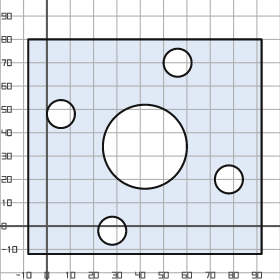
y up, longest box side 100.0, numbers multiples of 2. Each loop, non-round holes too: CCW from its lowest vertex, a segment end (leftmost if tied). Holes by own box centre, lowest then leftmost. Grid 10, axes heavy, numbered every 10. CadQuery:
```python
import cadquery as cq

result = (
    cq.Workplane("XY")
    .moveTo(-8.0, -12.0)
    .lineTo(92.0, -12.0)
    .lineTo(92.0, 80.0)
    .lineTo(-8.0, 80.0)
    .close()
    .moveTo(28.0, -2.0)
    .circle(6.0)
    .moveTo(78.0, 20.0)
    .circle(6.0)
    .moveTo(42.0, 34.0)
    .circle(18.0)
    .moveTo(6.0, 48.0)
    .circle(6.0)
    .moveTo(56.0, 70.0)
    .circle(6.0)
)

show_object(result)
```